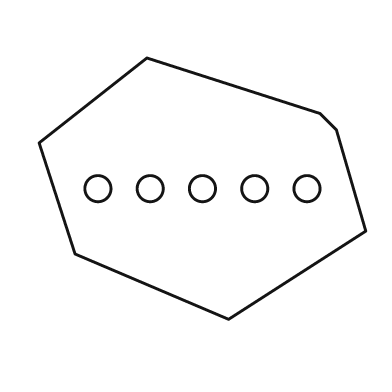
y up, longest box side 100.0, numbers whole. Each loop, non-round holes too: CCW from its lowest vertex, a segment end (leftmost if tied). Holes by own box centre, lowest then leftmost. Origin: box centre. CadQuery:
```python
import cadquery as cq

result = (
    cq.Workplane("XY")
    .moveTo(8.0, -40.0)
    .lineTo(50.0, -13.0)
    .lineTo(41.0, 18.0)
    .lineTo(36.0, 23.0)
    .lineTo(-17.0, 40.0)
    .lineTo(-50.0, 14.0)
    .lineTo(-39.0, -20.0)
    .close()
    .moveTo(-32.0, 0.0)
    .circle(4.0)
    .moveTo(-16.0, 0.0)
    .circle(4.0)
    .moveTo(0.0, 0.0)
    .circle(4.0)
    .moveTo(16.0, 0.0)
    .circle(4.0)
    .moveTo(32.0, 0.0)
    .circle(4.0)
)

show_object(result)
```